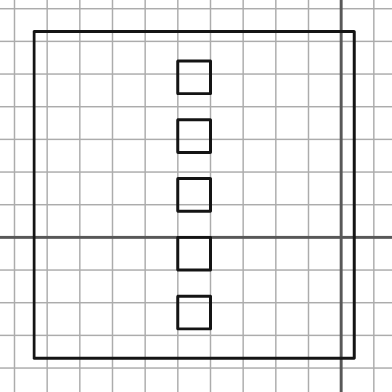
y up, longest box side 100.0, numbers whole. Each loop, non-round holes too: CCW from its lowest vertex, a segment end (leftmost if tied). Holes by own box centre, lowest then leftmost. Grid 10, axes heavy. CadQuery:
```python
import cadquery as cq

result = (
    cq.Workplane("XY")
    .moveTo(-94.0, -37.0)
    .lineTo(4.0, -37.0)
    .lineTo(4.0, 63.0)
    .lineTo(-94.0, 63.0)
    .close()
    .moveTo(-50.0, -28.0)
    .lineTo(-40.0, -28.0)
    .lineTo(-40.0, -18.0)
    .lineTo(-50.0, -18.0)
    .close()
    .moveTo(-50.0, -10.0)
    .lineTo(-40.0, -10.0)
    .lineTo(-40.0, 0.0)
    .lineTo(-50.0, 0.0)
    .close()
    .moveTo(-50.0, 8.0)
    .lineTo(-40.0, 8.0)
    .lineTo(-40.0, 18.0)
    .lineTo(-50.0, 18.0)
    .close()
    .moveTo(-50.0, 26.0)
    .lineTo(-40.0, 26.0)
    .lineTo(-40.0, 36.0)
    .lineTo(-50.0, 36.0)
    .close()
    .moveTo(-50.0, 44.0)
    .lineTo(-40.0, 44.0)
    .lineTo(-40.0, 54.0)
    .lineTo(-50.0, 54.0)
    .close()
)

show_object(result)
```